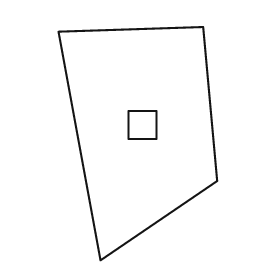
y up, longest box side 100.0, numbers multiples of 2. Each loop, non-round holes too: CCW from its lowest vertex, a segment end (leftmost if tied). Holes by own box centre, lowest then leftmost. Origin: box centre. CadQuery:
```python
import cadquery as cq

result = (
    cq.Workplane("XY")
    .moveTo(-16.0, -50.0)
    .lineTo(34.0, -16.0)
    .lineTo(28.0, 50.0)
    .lineTo(-34.0, 48.0)
    .close()
    .moveTo(-4.0, 2.0)
    .lineTo(8.0, 2.0)
    .lineTo(8.0, 14.0)
    .lineTo(-4.0, 14.0)
    .close()
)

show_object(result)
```